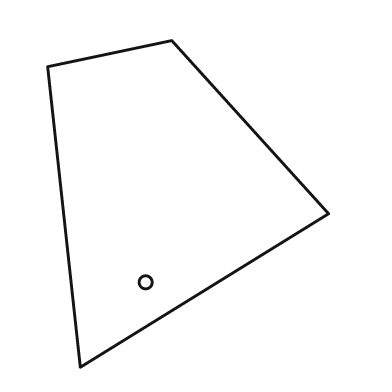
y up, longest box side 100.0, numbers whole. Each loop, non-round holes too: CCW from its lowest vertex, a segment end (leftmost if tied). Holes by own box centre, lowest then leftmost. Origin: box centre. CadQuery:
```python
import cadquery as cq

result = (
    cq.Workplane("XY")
    .moveTo(-33.0, -50.0)
    .lineTo(43.0, -3.0)
    .lineTo(-5.0, 50.0)
    .lineTo(-43.0, 42.0)
    .close()
    .moveTo(-13.0, -24.0)
    .circle(2.0)
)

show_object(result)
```